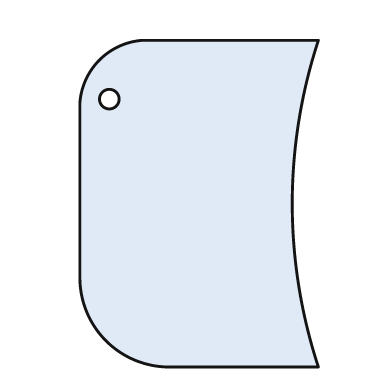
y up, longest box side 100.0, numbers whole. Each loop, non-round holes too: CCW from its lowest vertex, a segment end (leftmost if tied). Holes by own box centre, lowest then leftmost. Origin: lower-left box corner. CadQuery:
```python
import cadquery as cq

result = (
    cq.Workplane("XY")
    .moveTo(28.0, 0.0)
    .lineTo(73.0, 0.0)
    .threePointArc((65.0, 50.0), (73.0, 100.0))
    .lineTo(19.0, 100.0)
    .threePointArc((6.0, 94.0), (0.0, 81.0))
    .lineTo(0.0, 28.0)
    .threePointArc((8.0, 8.0), (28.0, 0.0))
    .close()
    .moveTo(9.0, 82.0)
    .circle(3.0)
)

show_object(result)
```